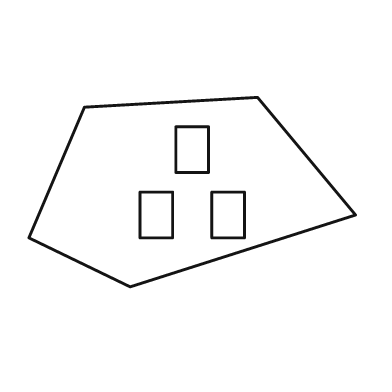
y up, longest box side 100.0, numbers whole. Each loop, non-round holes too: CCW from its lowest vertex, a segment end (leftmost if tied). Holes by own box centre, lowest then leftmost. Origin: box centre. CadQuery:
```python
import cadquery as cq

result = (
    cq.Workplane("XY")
    .moveTo(-19.0, -29.0)
    .lineTo(50.0, -7.0)
    .lineTo(20.0, 29.0)
    .lineTo(-33.0, 26.0)
    .lineTo(-50.0, -14.0)
    .close()
    .moveTo(-16.0, -14.0)
    .lineTo(-6.0, -14.0)
    .lineTo(-6.0, 0.0)
    .lineTo(-16.0, 0.0)
    .close()
    .moveTo(6.0, -14.0)
    .lineTo(16.0, -14.0)
    .lineTo(16.0, 0.0)
    .lineTo(6.0, 0.0)
    .close()
    .moveTo(-5.0, 6.0)
    .lineTo(5.0, 6.0)
    .lineTo(5.0, 20.0)
    .lineTo(-5.0, 20.0)
    .close()
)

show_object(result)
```